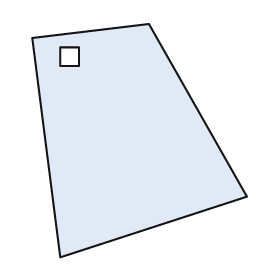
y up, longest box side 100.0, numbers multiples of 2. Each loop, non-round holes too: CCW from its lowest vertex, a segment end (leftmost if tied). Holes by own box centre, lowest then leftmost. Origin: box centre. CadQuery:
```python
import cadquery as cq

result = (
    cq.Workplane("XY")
    .moveTo(-34.0, -50.0)
    .lineTo(46.0, -24.0)
    .lineTo(4.0, 50.0)
    .lineTo(-46.0, 44.0)
    .close()
    .moveTo(-34.0, 32.0)
    .lineTo(-26.0, 32.0)
    .lineTo(-26.0, 40.0)
    .lineTo(-34.0, 40.0)
    .close()
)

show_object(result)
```